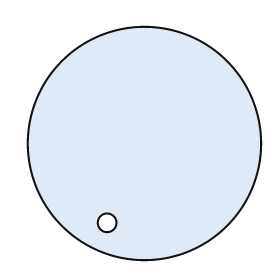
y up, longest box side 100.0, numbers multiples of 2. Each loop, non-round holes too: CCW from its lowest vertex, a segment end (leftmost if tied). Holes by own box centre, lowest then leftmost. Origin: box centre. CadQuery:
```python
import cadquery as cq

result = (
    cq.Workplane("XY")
    .moveTo(0.0, 0.0)
    .circle(50.0)
    .moveTo(-16.0, -34.0)
    .circle(4.0)
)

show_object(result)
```